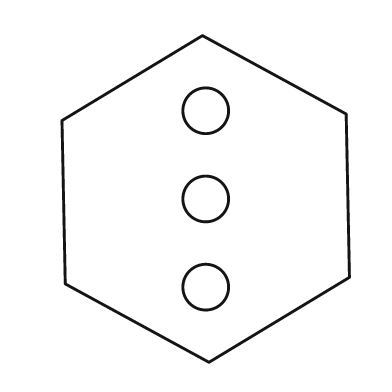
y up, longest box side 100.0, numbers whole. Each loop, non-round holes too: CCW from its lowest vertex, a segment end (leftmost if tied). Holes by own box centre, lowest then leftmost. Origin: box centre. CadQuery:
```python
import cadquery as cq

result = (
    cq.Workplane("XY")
    .moveTo(1.0, -50.0)
    .lineTo(44.0, -24.0)
    .lineTo(43.0, 26.0)
    .lineTo(-1.0, 50.0)
    .lineTo(-44.0, 24.0)
    .lineTo(-43.0, -26.0)
    .close()
    .moveTo(0.0, -27.0)
    .circle(7.0)
    .moveTo(0.0, 0.0)
    .circle(7.0)
    .moveTo(0.0, 27.0)
    .circle(7.0)
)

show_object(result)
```